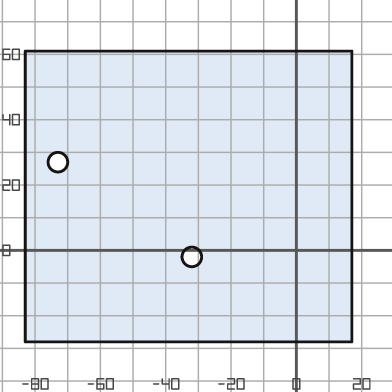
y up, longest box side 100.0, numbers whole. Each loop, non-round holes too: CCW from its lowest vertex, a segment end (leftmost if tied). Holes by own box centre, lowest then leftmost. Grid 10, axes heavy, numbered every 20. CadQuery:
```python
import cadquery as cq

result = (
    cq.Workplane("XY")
    .moveTo(-83.0, -28.0)
    .lineTo(17.0, -28.0)
    .lineTo(17.0, 61.0)
    .lineTo(-83.0, 61.0)
    .close()
    .moveTo(-32.0, -2.0)
    .circle(3.0)
    .moveTo(-73.0, 27.0)
    .circle(3.0)
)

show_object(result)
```